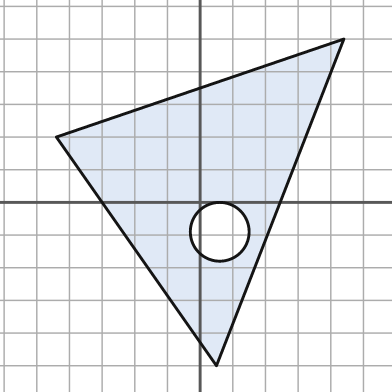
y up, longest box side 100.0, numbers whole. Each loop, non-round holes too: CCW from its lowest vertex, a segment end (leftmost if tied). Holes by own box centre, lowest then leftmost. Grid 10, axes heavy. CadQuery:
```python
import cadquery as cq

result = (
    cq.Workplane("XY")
    .moveTo(5.0, -50.0)
    .lineTo(44.0, 50.0)
    .lineTo(-44.0, 20.0)
    .close()
    .moveTo(6.0, -9.0)
    .circle(9.0)
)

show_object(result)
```